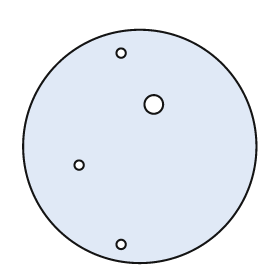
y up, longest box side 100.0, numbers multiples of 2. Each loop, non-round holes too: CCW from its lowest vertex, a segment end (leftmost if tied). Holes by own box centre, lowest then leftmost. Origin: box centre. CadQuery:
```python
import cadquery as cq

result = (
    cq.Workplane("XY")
    .moveTo(0.0, 0.0)
    .circle(50.0)
    .moveTo(-8.0, -42.0)
    .circle(2.0)
    .moveTo(-26.0, -8.0)
    .circle(2.0)
    .moveTo(6.0, 18.0)
    .circle(4.0)
    .moveTo(-8.0, 40.0)
    .circle(2.0)
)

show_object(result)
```